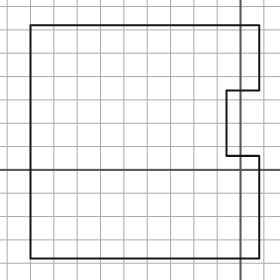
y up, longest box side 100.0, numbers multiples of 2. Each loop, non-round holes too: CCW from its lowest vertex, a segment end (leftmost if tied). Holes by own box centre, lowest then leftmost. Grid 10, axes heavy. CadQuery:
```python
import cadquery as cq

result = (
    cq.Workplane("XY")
    .moveTo(-90.0, -38.0)
    .lineTo(8.0, -38.0)
    .lineTo(8.0, 6.0)
    .lineTo(-6.0, 6.0)
    .lineTo(-6.0, 34.0)
    .lineTo(8.0, 34.0)
    .lineTo(8.0, 62.0)
    .lineTo(-90.0, 62.0)
    .close()
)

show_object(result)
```